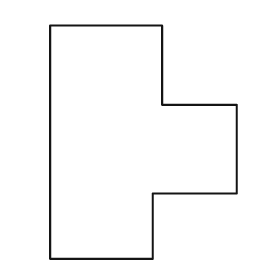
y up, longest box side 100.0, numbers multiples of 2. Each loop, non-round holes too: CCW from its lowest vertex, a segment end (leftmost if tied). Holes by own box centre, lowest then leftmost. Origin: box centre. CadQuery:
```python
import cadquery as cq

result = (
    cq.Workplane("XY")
    .moveTo(-40.0, -50.0)
    .lineTo(4.0, -50.0)
    .lineTo(4.0, -22.0)
    .lineTo(40.0, -22.0)
    .lineTo(40.0, 16.0)
    .lineTo(8.0, 16.0)
    .lineTo(8.0, 50.0)
    .lineTo(-40.0, 50.0)
    .close()
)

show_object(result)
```